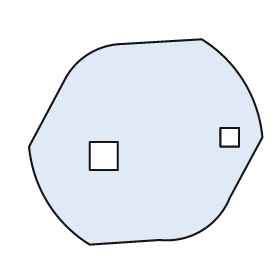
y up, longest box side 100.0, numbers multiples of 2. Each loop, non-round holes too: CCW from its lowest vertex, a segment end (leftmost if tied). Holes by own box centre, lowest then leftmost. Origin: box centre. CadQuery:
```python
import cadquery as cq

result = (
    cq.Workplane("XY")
    .moveTo(-24.0, -44.0)
    .lineTo(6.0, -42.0)
    .threePointArc((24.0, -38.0), (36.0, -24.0))
    .lineTo(50.0, 2.0)
    .threePointArc((42.0, 26.0), (24.0, 44.0))
    .lineTo(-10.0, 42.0)
    .threePointArc((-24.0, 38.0), (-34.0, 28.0))
    .lineTo(-50.0, -2.0)
    .threePointArc((-42.0, -26.0), (-24.0, -44.0))
    .close()
    .moveTo(-24.0, -12.0)
    .lineTo(-12.0, -12.0)
    .lineTo(-12.0, 0.0)
    .lineTo(-24.0, 0.0)
    .close()
    .moveTo(32.0, -2.0)
    .lineTo(40.0, -2.0)
    .lineTo(40.0, 6.0)
    .lineTo(32.0, 6.0)
    .close()
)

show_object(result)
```